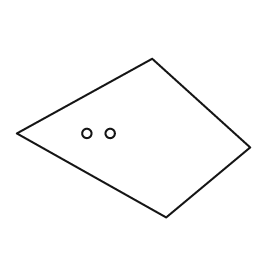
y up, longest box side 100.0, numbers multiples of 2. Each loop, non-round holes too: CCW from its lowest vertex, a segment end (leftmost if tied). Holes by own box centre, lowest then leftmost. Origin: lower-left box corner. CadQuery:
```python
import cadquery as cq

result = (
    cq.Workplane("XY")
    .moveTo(64.0, 0.0)
    .lineTo(100.0, 30.0)
    .lineTo(58.0, 68.0)
    .lineTo(0.0, 36.0)
    .close()
    .moveTo(30.0, 36.0)
    .circle(2.0)
    .moveTo(40.0, 36.0)
    .circle(2.0)
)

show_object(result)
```